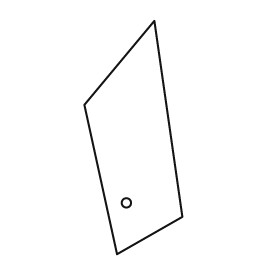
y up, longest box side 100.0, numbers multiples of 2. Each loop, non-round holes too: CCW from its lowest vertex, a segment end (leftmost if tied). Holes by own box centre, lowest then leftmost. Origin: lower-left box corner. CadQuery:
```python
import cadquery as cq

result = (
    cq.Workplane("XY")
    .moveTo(14.0, 0.0)
    .lineTo(42.0, 16.0)
    .lineTo(30.0, 100.0)
    .lineTo(0.0, 64.0)
    .close()
    .moveTo(18.0, 22.0)
    .circle(2.0)
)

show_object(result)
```